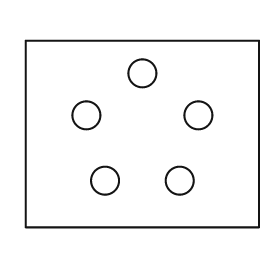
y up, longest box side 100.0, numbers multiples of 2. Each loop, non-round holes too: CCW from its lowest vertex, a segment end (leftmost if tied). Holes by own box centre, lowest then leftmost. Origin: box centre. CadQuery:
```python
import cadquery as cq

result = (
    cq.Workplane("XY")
    .moveTo(-50.0, -40.0)
    .lineTo(50.0, -40.0)
    .lineTo(50.0, 40.0)
    .lineTo(-50.0, 40.0)
    .close()
    .moveTo(-16.0, -20.0)
    .circle(6.0)
    .moveTo(16.0, -20.0)
    .circle(6.0)
    .moveTo(-24.0, 8.0)
    .circle(6.0)
    .moveTo(24.0, 8.0)
    .circle(6.0)
    .moveTo(0.0, 26.0)
    .circle(6.0)
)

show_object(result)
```